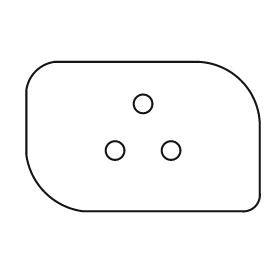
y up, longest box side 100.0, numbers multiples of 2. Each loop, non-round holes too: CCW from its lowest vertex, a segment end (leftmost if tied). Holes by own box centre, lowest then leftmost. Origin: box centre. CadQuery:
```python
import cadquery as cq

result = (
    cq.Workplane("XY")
    .moveTo(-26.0, -32.0)
    .lineTo(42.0, -32.0)
    .threePointArc((48.0, -30.0), (50.0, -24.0))
    .lineTo(50.0, 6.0)
    .threePointArc((42.0, 24.0), (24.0, 32.0))
    .lineTo(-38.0, 32.0)
    .threePointArc((-46.0, 28.0), (-50.0, 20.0))
    .lineTo(-50.0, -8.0)
    .threePointArc((-42.0, -24.0), (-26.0, -32.0))
    .close()
    .moveTo(-12.0, -6.0)
    .circle(4.0)
    .moveTo(12.0, -6.0)
    .circle(4.0)
    .moveTo(0.0, 14.0)
    .circle(4.0)
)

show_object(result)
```